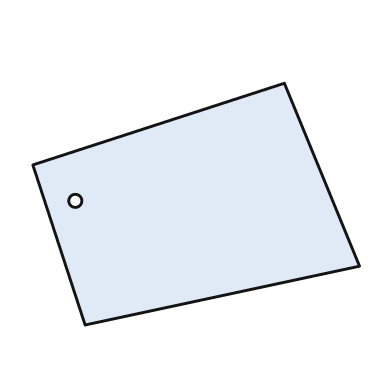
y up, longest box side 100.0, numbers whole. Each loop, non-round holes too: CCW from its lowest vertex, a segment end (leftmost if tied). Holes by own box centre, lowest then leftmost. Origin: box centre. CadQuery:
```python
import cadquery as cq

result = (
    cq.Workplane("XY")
    .moveTo(-34.0, -37.0)
    .lineTo(50.0, -19.0)
    .lineTo(27.0, 37.0)
    .lineTo(-50.0, 12.0)
    .close()
    .moveTo(-37.0, 1.0)
    .circle(2.0)
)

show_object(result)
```